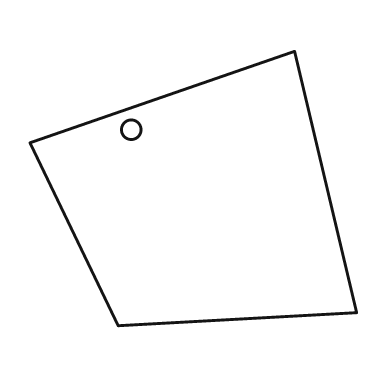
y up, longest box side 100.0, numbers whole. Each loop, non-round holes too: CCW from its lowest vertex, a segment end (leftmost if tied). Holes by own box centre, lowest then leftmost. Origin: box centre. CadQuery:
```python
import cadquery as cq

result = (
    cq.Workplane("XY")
    .moveTo(-23.0, -42.0)
    .lineTo(50.0, -38.0)
    .lineTo(31.0, 42.0)
    .lineTo(-50.0, 14.0)
    .close()
    .moveTo(-19.0, 18.0)
    .circle(3.0)
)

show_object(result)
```